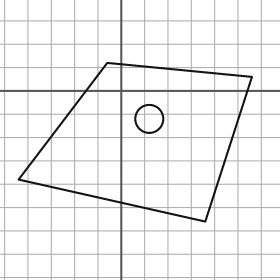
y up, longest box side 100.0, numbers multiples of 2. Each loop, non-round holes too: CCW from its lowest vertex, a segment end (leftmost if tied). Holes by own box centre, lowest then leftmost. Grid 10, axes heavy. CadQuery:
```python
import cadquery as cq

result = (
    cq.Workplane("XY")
    .moveTo(36.0, -56.0)
    .lineTo(56.0, 6.0)
    .lineTo(-6.0, 12.0)
    .lineTo(-44.0, -38.0)
    .close()
    .moveTo(12.0, -12.0)
    .circle(6.0)
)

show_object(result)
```